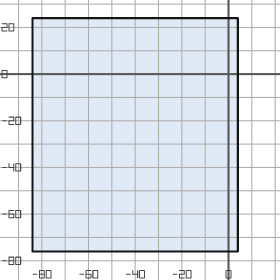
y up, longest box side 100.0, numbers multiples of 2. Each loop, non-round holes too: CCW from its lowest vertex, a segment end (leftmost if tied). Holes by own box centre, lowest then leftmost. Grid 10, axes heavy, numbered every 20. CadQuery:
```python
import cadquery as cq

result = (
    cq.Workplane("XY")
    .moveTo(-84.0, -76.0)
    .lineTo(4.0, -76.0)
    .lineTo(4.0, 24.0)
    .lineTo(-84.0, 24.0)
    .close()
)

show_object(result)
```